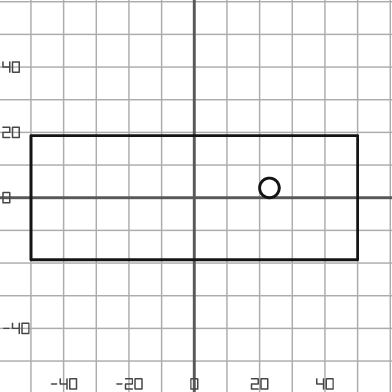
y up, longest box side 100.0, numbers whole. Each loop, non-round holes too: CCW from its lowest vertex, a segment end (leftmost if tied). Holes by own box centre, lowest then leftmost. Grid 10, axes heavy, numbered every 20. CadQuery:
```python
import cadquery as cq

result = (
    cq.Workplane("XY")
    .moveTo(-50.0, -19.0)
    .lineTo(50.0, -19.0)
    .lineTo(50.0, 19.0)
    .lineTo(-50.0, 19.0)
    .close()
    .moveTo(23.0, 3.0)
    .circle(3.0)
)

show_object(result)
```